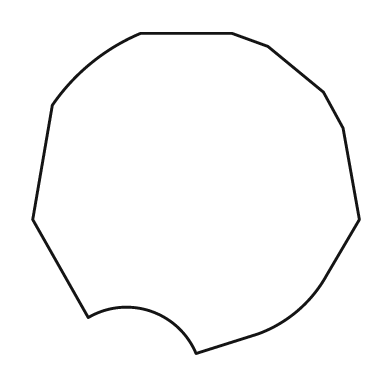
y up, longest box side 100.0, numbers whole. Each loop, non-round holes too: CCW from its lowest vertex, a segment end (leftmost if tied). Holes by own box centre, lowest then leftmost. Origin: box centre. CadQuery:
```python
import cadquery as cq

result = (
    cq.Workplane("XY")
    .moveTo(0.0, -49.0)
    .lineTo(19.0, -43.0)
    .threePointArc((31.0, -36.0), (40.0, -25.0))
    .lineTo(50.0, -8.0)
    .lineTo(45.0, 20.0)
    .lineTo(39.0, 31.0)
    .lineTo(22.0, 45.0)
    .lineTo(11.0, 49.0)
    .lineTo(-17.0, 49.0)
    .threePointArc((-32.0, 40.0), (-44.0, 27.0))
    .lineTo(-50.0, -8.0)
    .lineTo(-33.0, -38.0)
    .threePointArc((-14.0, -36.0), (0.0, -49.0))
    .close()
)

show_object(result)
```